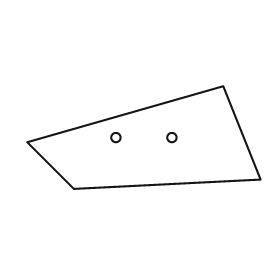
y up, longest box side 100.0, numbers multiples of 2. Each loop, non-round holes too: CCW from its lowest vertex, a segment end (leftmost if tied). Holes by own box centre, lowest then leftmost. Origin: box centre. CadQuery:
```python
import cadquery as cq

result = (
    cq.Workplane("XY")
    .moveTo(-30.0, -22.0)
    .lineTo(50.0, -18.0)
    .lineTo(34.0, 22.0)
    .lineTo(-50.0, -2.0)
    .close()
    .moveTo(-12.0, 0.0)
    .circle(2.0)
    .moveTo(12.0, 0.0)
    .circle(2.0)
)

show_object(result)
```